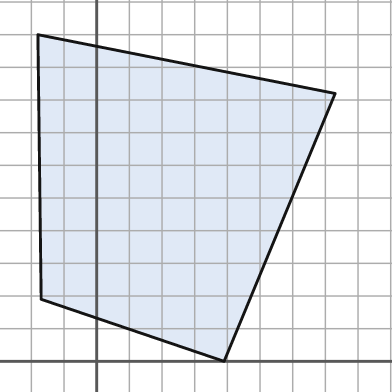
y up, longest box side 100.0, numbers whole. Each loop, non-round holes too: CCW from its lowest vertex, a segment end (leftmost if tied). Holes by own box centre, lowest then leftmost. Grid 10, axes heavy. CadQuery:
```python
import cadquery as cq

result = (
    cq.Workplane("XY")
    .moveTo(39.0, 0.0)
    .lineTo(73.0, 82.0)
    .lineTo(-18.0, 100.0)
    .lineTo(-17.0, 19.0)
    .close()
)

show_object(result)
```